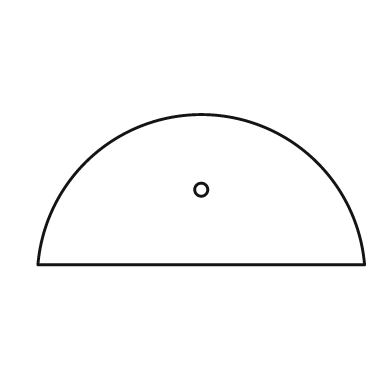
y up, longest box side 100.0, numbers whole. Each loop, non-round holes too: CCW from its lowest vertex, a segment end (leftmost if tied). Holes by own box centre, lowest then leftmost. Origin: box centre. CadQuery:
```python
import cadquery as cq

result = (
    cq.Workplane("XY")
    .moveTo(-50.0, -23.0)
    .lineTo(50.0, -23.0)
    .threePointArc((0.0, 23.0), (-50.0, -23.0))
    .close()
    .moveTo(0.0, 0.0)
    .circle(2.0)
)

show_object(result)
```